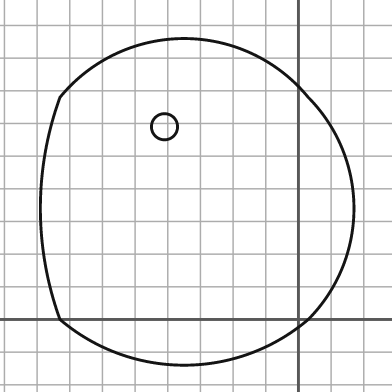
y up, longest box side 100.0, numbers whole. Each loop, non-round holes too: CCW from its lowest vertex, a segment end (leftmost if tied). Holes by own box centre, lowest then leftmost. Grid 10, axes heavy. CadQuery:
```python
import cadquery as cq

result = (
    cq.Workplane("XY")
    .moveTo(-73.0, 0.0)
    .threePointArc((-35.0, -14.0), (3.0, 0.0))
    .threePointArc((17.0, 34.0), (3.0, 68.0))
    .threePointArc((-35.0, 86.0), (-73.0, 68.0))
    .threePointArc((-79.0, 34.0), (-73.0, 0.0))
    .close()
    .moveTo(-41.0, 59.0)
    .circle(4.0)
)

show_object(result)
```